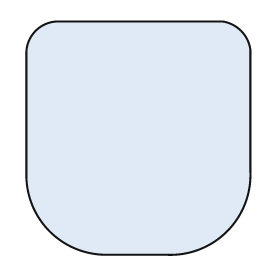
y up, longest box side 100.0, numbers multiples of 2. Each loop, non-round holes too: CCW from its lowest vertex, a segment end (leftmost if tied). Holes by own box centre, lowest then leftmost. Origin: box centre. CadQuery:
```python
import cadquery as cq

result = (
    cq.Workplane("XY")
    .moveTo(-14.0, -50.0)
    .lineTo(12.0, -50.0)
    .threePointArc((38.0, -40.0), (48.0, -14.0))
    .lineTo(48.0, 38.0)
    .threePointArc((44.0, 46.0), (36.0, 50.0))
    .lineTo(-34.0, 50.0)
    .threePointArc((-44.0, 46.0), (-48.0, 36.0))
    .lineTo(-48.0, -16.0)
    .threePointArc((-38.0, -40.0), (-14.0, -50.0))
    .close()
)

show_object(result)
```